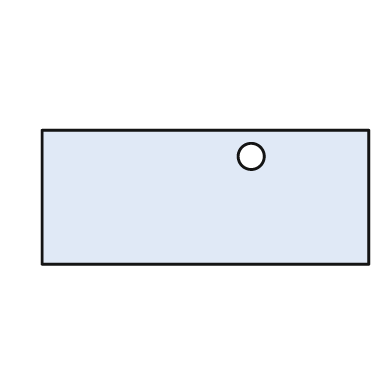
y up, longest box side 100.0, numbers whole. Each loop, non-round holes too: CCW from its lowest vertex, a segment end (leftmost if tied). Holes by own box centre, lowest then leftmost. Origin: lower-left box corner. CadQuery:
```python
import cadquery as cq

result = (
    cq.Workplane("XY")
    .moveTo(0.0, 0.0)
    .lineTo(100.0, 0.0)
    .lineTo(100.0, 41.0)
    .lineTo(0.0, 41.0)
    .close()
    .moveTo(64.0, 33.0)
    .circle(4.0)
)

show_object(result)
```